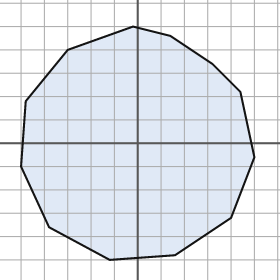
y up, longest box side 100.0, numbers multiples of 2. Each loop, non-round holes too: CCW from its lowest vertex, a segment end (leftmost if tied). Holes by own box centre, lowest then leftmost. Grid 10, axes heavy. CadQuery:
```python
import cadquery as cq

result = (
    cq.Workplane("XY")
    .moveTo(-12.0, -50.0)
    .lineTo(16.0, -48.0)
    .lineTo(40.0, -32.0)
    .lineTo(50.0, -6.0)
    .lineTo(44.0, 22.0)
    .lineTo(32.0, 34.0)
    .lineTo(14.0, 46.0)
    .lineTo(-2.0, 50.0)
    .lineTo(-30.0, 40.0)
    .lineTo(-48.0, 18.0)
    .lineTo(-50.0, -10.0)
    .lineTo(-38.0, -36.0)
    .close()
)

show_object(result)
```